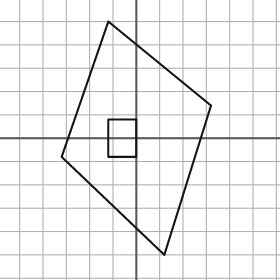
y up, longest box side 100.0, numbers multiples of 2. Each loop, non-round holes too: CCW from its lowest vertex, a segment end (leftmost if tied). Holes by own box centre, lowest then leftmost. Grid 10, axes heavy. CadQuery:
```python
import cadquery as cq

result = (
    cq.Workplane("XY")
    .moveTo(12.0, -50.0)
    .lineTo(32.0, 14.0)
    .lineTo(-12.0, 50.0)
    .lineTo(-32.0, -8.0)
    .close()
    .moveTo(-12.0, -8.0)
    .lineTo(0.0, -8.0)
    .lineTo(0.0, 8.0)
    .lineTo(-12.0, 8.0)
    .close()
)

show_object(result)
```